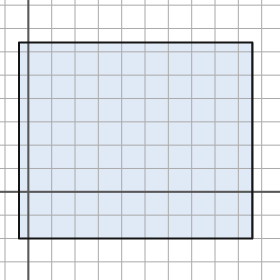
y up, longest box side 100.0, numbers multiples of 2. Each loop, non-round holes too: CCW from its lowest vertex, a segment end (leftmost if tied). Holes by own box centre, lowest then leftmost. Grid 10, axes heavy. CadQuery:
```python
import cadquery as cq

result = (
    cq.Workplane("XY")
    .moveTo(-4.0, -20.0)
    .lineTo(96.0, -20.0)
    .lineTo(96.0, 64.0)
    .lineTo(-4.0, 64.0)
    .close()
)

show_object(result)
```